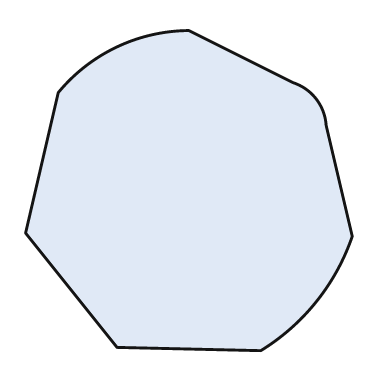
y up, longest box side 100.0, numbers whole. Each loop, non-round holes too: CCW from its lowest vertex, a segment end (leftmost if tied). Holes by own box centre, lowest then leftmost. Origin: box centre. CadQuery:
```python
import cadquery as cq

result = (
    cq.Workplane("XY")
    .moveTo(22.0, -49.0)
    .threePointArc((39.0, -34.0), (50.0, -14.0))
    .lineTo(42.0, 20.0)
    .threePointArc((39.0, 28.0), (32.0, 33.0))
    .lineTo(0.0, 49.0)
    .threePointArc((-22.0, 44.0), (-40.0, 30.0))
    .lineTo(-50.0, -13.0)
    .lineTo(-22.0, -48.0)
    .close()
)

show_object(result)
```